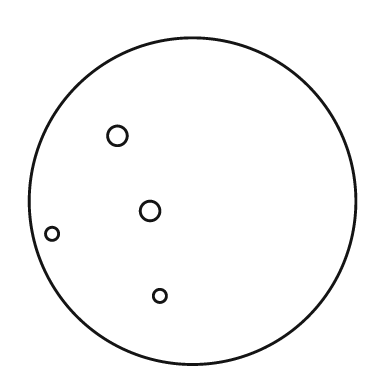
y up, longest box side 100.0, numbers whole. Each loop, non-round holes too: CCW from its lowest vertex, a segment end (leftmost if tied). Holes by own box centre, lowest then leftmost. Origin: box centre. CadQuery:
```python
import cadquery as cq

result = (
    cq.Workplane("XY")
    .moveTo(0.0, 0.0)
    .circle(50.0)
    .moveTo(-10.0, -29.0)
    .circle(2.0)
    .moveTo(-43.0, -10.0)
    .circle(2.0)
    .moveTo(-13.0, -3.0)
    .circle(3.0)
    .moveTo(-23.0, 20.0)
    .circle(3.0)
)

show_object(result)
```